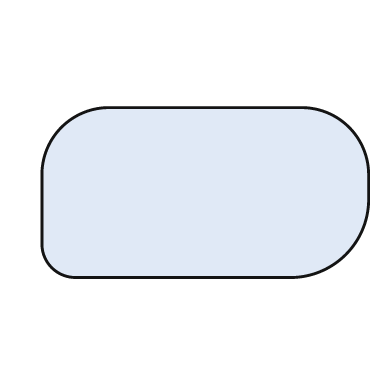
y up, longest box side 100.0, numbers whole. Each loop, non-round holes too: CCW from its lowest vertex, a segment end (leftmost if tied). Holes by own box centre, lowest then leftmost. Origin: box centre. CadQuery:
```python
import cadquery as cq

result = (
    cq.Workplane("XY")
    .moveTo(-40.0, -26.0)
    .lineTo(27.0, -26.0)
    .threePointArc((43.0, -19.0), (50.0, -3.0))
    .lineTo(50.0, 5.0)
    .threePointArc((44.0, 20.0), (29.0, 26.0))
    .lineTo(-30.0, 26.0)
    .threePointArc((-44.0, 20.0), (-50.0, 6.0))
    .lineTo(-50.0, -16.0)
    .threePointArc((-47.0, -23.0), (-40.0, -26.0))
    .close()
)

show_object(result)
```